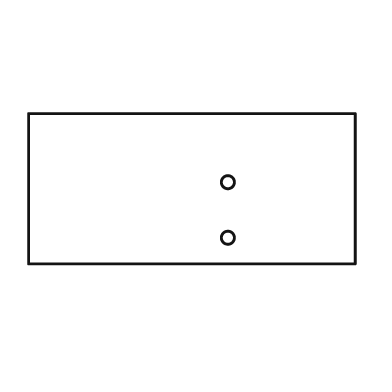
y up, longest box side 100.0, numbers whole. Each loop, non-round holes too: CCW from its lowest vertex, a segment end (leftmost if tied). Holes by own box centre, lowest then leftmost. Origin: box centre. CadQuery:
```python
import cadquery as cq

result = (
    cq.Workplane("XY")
    .moveTo(-50.0, -23.0)
    .lineTo(50.0, -23.0)
    .lineTo(50.0, 23.0)
    .lineTo(-50.0, 23.0)
    .close()
    .moveTo(11.0, -15.0)
    .circle(2.0)
    .moveTo(11.0, 2.0)
    .circle(2.0)
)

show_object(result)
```